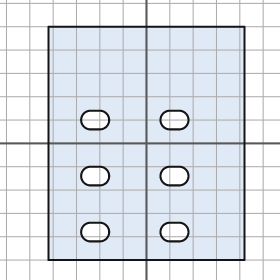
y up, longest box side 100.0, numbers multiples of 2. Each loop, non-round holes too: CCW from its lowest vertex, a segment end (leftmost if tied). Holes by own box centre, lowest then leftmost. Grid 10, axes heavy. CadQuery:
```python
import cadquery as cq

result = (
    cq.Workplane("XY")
    .moveTo(-42.0, -50.0)
    .lineTo(42.0, -50.0)
    .lineTo(42.0, 50.0)
    .lineTo(-42.0, 50.0)
    .close()
    .moveTo(-24.0, -42.0)
    .lineTo(-20.0, -42.0)
    .threePointArc((-16.0, -38.0), (-20.0, -34.0))
    .lineTo(-24.0, -34.0)
    .threePointArc((-28.0, -38.0), (-24.0, -42.0))
    .close()
    .moveTo(10.0, -42.0)
    .lineTo(14.0, -42.0)
    .threePointArc((18.0, -38.0), (14.0, -34.0))
    .lineTo(10.0, -34.0)
    .threePointArc((6.0, -38.0), (10.0, -42.0))
    .close()
    .moveTo(-24.0, -18.0)
    .lineTo(-20.0, -18.0)
    .threePointArc((-16.0, -14.0), (-20.0, -10.0))
    .lineTo(-24.0, -10.0)
    .threePointArc((-28.0, -14.0), (-24.0, -18.0))
    .close()
    .moveTo(10.0, -18.0)
    .lineTo(14.0, -18.0)
    .threePointArc((18.0, -14.0), (14.0, -10.0))
    .lineTo(10.0, -10.0)
    .threePointArc((6.0, -14.0), (10.0, -18.0))
    .close()
    .moveTo(-24.0, 6.0)
    .lineTo(-20.0, 6.0)
    .threePointArc((-16.0, 10.0), (-20.0, 14.0))
    .lineTo(-24.0, 14.0)
    .threePointArc((-28.0, 10.0), (-24.0, 6.0))
    .close()
    .moveTo(10.0, 6.0)
    .lineTo(14.0, 6.0)
    .threePointArc((18.0, 10.0), (14.0, 14.0))
    .lineTo(10.0, 14.0)
    .threePointArc((6.0, 10.0), (10.0, 6.0))
    .close()
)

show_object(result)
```